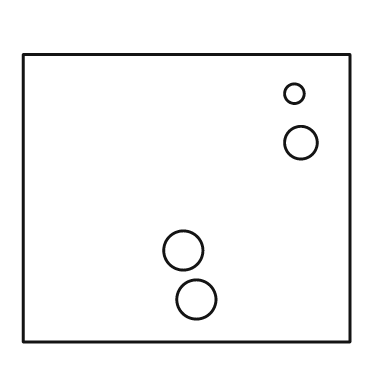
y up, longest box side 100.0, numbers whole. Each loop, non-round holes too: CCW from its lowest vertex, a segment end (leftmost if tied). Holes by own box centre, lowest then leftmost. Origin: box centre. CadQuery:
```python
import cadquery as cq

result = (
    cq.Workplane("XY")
    .moveTo(-50.0, -44.0)
    .lineTo(50.0, -44.0)
    .lineTo(50.0, 44.0)
    .lineTo(-50.0, 44.0)
    .close()
    .moveTo(3.0, -31.0)
    .circle(6.0)
    .moveTo(-1.0, -16.0)
    .circle(6.0)
    .moveTo(35.0, 17.0)
    .circle(5.0)
    .moveTo(33.0, 32.0)
    .circle(3.0)
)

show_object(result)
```